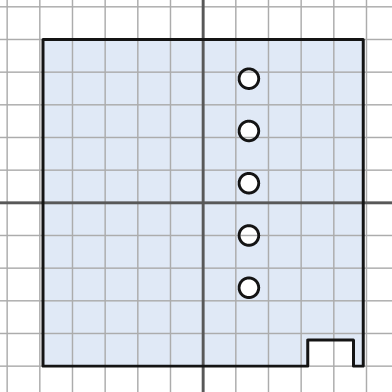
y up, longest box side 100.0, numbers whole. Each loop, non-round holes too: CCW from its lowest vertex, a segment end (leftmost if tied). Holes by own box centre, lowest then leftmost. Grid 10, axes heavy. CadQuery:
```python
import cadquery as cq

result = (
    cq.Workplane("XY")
    .moveTo(-49.0, -50.0)
    .lineTo(32.0, -50.0)
    .lineTo(32.0, -42.0)
    .lineTo(46.0, -42.0)
    .lineTo(46.0, -50.0)
    .lineTo(49.0, -50.0)
    .lineTo(49.0, 50.0)
    .lineTo(-49.0, 50.0)
    .close()
    .moveTo(14.0, -26.0)
    .circle(3.0)
    .moveTo(14.0, -10.0)
    .circle(3.0)
    .moveTo(14.0, 6.0)
    .circle(3.0)
    .moveTo(14.0, 22.0)
    .circle(3.0)
    .moveTo(14.0, 38.0)
    .circle(3.0)
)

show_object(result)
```